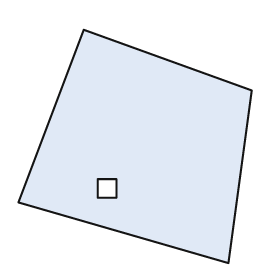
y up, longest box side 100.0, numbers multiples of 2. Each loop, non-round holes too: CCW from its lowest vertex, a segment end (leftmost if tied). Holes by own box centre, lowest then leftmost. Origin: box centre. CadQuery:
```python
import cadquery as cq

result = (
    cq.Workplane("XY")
    .moveTo(40.0, -50.0)
    .lineTo(50.0, 24.0)
    .lineTo(-22.0, 50.0)
    .lineTo(-50.0, -24.0)
    .close()
    .moveTo(-16.0, -22.0)
    .lineTo(-8.0, -22.0)
    .lineTo(-8.0, -14.0)
    .lineTo(-16.0, -14.0)
    .close()
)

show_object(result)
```